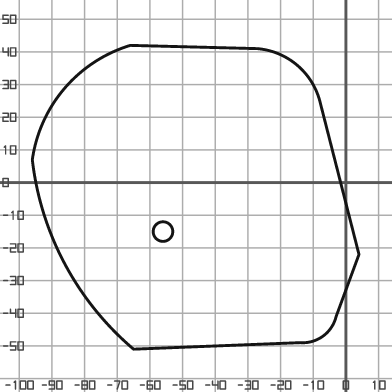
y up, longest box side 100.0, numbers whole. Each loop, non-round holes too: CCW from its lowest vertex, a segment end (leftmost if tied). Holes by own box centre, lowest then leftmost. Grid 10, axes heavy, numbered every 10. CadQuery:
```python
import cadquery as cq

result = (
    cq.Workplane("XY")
    .moveTo(-65.0, -51.0)
    .lineTo(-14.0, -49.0)
    .threePointArc((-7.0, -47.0), (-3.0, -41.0))
    .lineTo(4.0, -22.0)
    .lineTo(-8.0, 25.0)
    .threePointArc((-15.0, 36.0), (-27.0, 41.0))
    .lineTo(-66.0, 42.0)
    .threePointArc((-86.0, 29.0), (-96.0, 7.0))
    .threePointArc((-86.0, -25.0), (-65.0, -51.0))
    .close()
    .moveTo(-56.0, -15.0)
    .circle(3.0)
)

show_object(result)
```